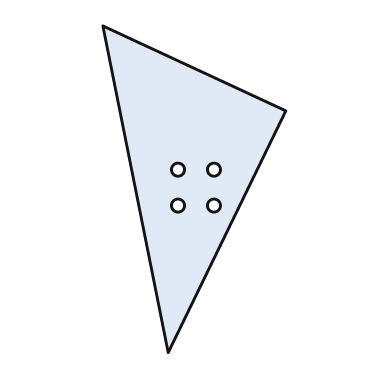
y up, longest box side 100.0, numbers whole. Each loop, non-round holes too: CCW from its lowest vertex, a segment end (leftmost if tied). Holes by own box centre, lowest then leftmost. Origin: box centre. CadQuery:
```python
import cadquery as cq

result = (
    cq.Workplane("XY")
    .moveTo(-8.0, -50.0)
    .lineTo(28.0, 24.0)
    .lineTo(-28.0, 50.0)
    .close()
    .moveTo(-5.0, -5.0)
    .circle(2.0)
    .moveTo(6.0, -5.0)
    .circle(2.0)
    .moveTo(-5.0, 6.0)
    .circle(2.0)
    .moveTo(6.0, 6.0)
    .circle(2.0)
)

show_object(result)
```